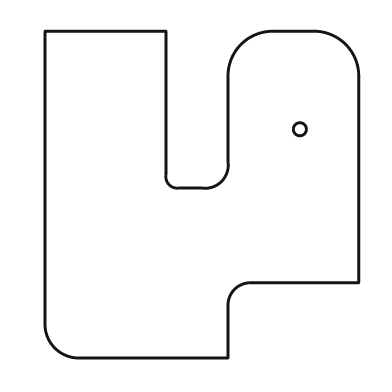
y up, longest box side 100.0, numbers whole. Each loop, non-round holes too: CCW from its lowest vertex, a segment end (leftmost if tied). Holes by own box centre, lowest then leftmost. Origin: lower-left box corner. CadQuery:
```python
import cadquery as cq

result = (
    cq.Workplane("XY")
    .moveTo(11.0, 0.0)
    .lineTo(56.0, 0.0)
    .lineTo(56.0, 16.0)
    .threePointArc((58.0, 21.0), (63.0, 23.0))
    .lineTo(96.0, 23.0)
    .lineTo(96.0, 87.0)
    .threePointArc((92.0, 96.0), (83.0, 100.0))
    .lineTo(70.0, 100.0)
    .threePointArc((60.0, 96.0), (56.0, 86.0))
    .lineTo(56.0, 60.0)
    .threePointArc((54.0, 54.0), (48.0, 52.0))
    .lineTo(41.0, 52.0)
    .threePointArc((38.0, 53.0), (37.0, 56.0))
    .lineTo(37.0, 100.0)
    .lineTo(0.0, 100.0)
    .lineTo(0.0, 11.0)
    .threePointArc((3.0, 3.0), (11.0, 0.0))
    .close()
    .moveTo(78.0, 70.0)
    .circle(2.0)
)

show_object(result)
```